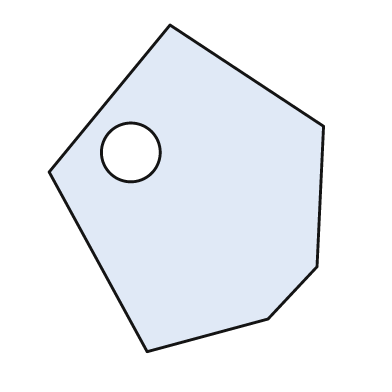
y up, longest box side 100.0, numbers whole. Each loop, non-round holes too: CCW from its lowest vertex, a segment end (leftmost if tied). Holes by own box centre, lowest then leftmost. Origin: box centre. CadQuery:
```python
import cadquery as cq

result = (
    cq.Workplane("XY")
    .moveTo(-12.0, -50.0)
    .lineTo(25.0, -40.0)
    .lineTo(40.0, -24.0)
    .lineTo(42.0, 19.0)
    .lineTo(-5.0, 50.0)
    .lineTo(-42.0, 5.0)
    .close()
    .moveTo(-17.0, 11.0)
    .circle(9.0)
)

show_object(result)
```